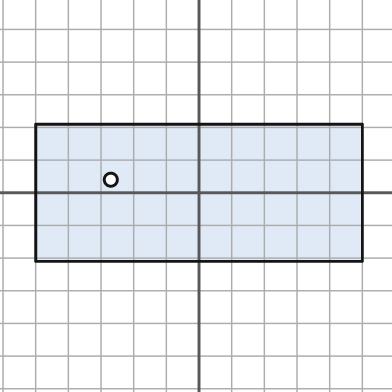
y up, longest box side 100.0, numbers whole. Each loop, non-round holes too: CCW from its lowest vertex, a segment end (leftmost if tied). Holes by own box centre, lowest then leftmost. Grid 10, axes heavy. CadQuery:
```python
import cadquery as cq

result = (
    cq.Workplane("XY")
    .moveTo(-50.0, -21.0)
    .lineTo(50.0, -21.0)
    .lineTo(50.0, 21.0)
    .lineTo(-50.0, 21.0)
    .close()
    .moveTo(-27.0, 4.0)
    .circle(2.0)
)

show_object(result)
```